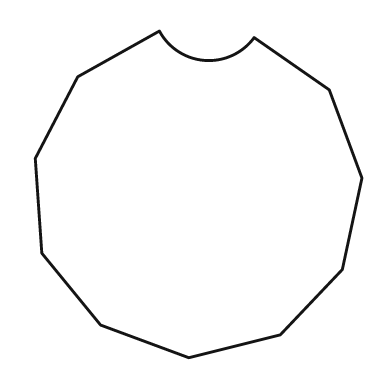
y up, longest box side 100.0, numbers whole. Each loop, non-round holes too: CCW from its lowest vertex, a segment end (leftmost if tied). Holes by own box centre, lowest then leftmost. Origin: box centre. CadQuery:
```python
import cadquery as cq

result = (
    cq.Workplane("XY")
    .moveTo(-3.0, -50.0)
    .lineTo(25.0, -43.0)
    .lineTo(44.0, -23.0)
    .lineTo(50.0, 5.0)
    .lineTo(40.0, 32.0)
    .lineTo(17.0, 48.0)
    .threePointArc((2.0, 41.0), (-12.0, 50.0))
    .lineTo(-37.0, 36.0)
    .lineTo(-50.0, 11.0)
    .lineTo(-48.0, -18.0)
    .lineTo(-30.0, -40.0)
    .close()
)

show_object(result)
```